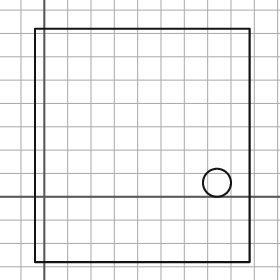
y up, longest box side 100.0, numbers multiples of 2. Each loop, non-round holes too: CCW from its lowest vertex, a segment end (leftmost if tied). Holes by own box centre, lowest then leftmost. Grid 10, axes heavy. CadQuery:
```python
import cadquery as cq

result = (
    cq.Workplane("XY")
    .moveTo(-4.0, -28.0)
    .lineTo(88.0, -28.0)
    .lineTo(88.0, 72.0)
    .lineTo(-4.0, 72.0)
    .close()
    .moveTo(74.0, 6.0)
    .circle(6.0)
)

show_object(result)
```